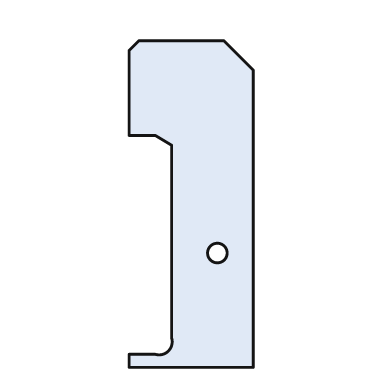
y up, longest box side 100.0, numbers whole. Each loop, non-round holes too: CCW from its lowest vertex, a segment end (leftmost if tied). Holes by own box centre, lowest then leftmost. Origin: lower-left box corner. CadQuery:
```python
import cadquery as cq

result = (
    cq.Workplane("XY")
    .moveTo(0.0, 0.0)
    .lineTo(38.0, 0.0)
    .lineTo(38.0, 91.0)
    .lineTo(29.0, 100.0)
    .lineTo(3.0, 100.0)
    .lineTo(0.0, 97.0)
    .lineTo(0.0, 71.0)
    .lineTo(8.0, 71.0)
    .lineTo(13.0, 68.0)
    .lineTo(13.0, 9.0)
    .threePointArc((12.0, 5.0), (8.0, 4.0))
    .lineTo(0.0, 4.0)
    .close()
    .moveTo(27.0, 35.0)
    .circle(3.0)
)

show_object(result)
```